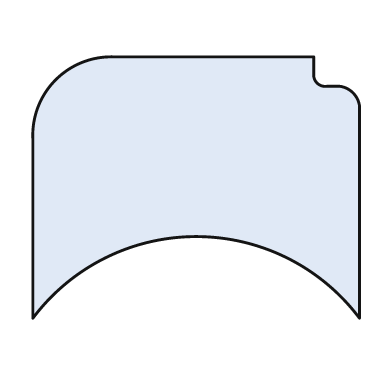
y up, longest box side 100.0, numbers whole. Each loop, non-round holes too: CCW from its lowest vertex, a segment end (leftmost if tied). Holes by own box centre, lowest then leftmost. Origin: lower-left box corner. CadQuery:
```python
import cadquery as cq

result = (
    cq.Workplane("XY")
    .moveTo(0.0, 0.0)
    .threePointArc((50.0, 25.0), (100.0, 0.0))
    .lineTo(100.0, 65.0)
    .threePointArc((98.0, 69.0), (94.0, 71.0))
    .lineTo(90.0, 71.0)
    .threePointArc((87.0, 72.0), (86.0, 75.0))
    .lineTo(86.0, 80.0)
    .lineTo(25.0, 80.0)
    .threePointArc((7.0, 73.0), (0.0, 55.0))
    .close()
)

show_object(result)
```